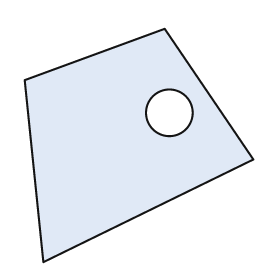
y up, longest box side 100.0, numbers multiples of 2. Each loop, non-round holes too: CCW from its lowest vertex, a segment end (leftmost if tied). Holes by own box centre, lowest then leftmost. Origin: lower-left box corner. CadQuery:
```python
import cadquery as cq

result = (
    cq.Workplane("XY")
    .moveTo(8.0, 0.0)
    .lineTo(98.0, 44.0)
    .lineTo(60.0, 100.0)
    .lineTo(0.0, 78.0)
    .close()
    .moveTo(62.0, 64.0)
    .circle(10.0)
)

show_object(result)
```